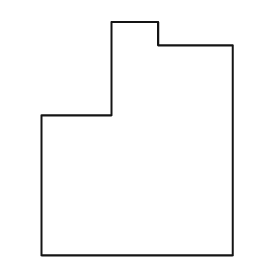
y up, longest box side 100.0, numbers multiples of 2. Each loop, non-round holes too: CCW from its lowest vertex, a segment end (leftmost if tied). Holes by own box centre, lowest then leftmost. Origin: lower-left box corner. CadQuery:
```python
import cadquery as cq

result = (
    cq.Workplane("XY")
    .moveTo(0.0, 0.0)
    .lineTo(82.0, 0.0)
    .lineTo(82.0, 90.0)
    .lineTo(50.0, 90.0)
    .lineTo(50.0, 100.0)
    .lineTo(30.0, 100.0)
    .lineTo(30.0, 60.0)
    .lineTo(0.0, 60.0)
    .close()
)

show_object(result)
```